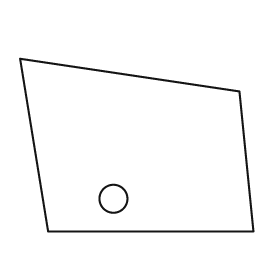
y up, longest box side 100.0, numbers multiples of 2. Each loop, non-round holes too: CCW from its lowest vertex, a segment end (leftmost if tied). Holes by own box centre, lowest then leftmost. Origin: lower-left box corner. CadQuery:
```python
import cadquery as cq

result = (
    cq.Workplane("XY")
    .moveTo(12.0, 0.0)
    .lineTo(100.0, 0.0)
    .lineTo(94.0, 60.0)
    .lineTo(0.0, 74.0)
    .close()
    .moveTo(40.0, 14.0)
    .circle(6.0)
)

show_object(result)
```